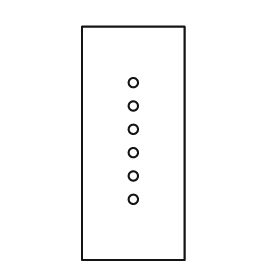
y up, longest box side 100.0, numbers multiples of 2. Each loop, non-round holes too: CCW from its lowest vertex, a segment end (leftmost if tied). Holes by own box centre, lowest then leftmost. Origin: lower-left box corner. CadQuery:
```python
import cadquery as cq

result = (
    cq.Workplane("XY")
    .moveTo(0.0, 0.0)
    .lineTo(44.0, 0.0)
    .lineTo(44.0, 100.0)
    .lineTo(0.0, 100.0)
    .close()
    .moveTo(22.0, 26.0)
    .circle(2.0)
    .moveTo(22.0, 36.0)
    .circle(2.0)
    .moveTo(22.0, 46.0)
    .circle(2.0)
    .moveTo(22.0, 56.0)
    .circle(2.0)
    .moveTo(22.0, 66.0)
    .circle(2.0)
    .moveTo(22.0, 76.0)
    .circle(2.0)
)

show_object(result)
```